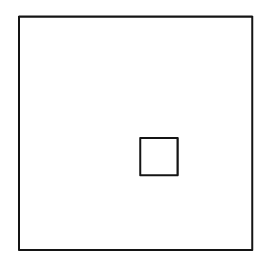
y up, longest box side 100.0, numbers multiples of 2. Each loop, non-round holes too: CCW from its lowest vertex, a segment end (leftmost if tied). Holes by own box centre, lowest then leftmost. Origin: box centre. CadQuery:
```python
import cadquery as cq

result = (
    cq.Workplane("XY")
    .moveTo(-50.0, -50.0)
    .lineTo(50.0, -50.0)
    .lineTo(50.0, 50.0)
    .lineTo(-50.0, 50.0)
    .close()
    .moveTo(2.0, -18.0)
    .lineTo(18.0, -18.0)
    .lineTo(18.0, -2.0)
    .lineTo(2.0, -2.0)
    .close()
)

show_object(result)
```